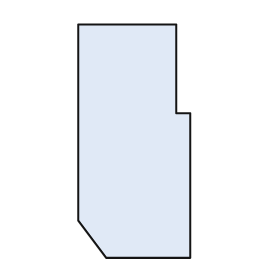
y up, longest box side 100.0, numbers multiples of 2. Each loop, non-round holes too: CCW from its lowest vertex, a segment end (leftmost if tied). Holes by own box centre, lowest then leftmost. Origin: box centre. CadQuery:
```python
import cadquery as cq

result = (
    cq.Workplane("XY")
    .moveTo(-12.0, -50.0)
    .lineTo(24.0, -50.0)
    .lineTo(24.0, 12.0)
    .lineTo(18.0, 12.0)
    .lineTo(18.0, 50.0)
    .lineTo(-24.0, 50.0)
    .lineTo(-24.0, -34.0)
    .close()
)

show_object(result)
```